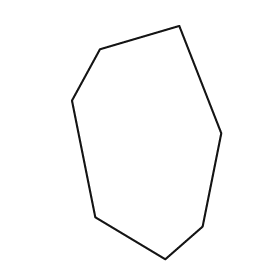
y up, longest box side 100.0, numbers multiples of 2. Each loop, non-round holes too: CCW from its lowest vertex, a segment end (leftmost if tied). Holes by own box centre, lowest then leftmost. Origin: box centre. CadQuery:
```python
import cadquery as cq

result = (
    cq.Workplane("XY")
    .moveTo(8.0, -50.0)
    .lineTo(24.0, -36.0)
    .lineTo(32.0, 4.0)
    .lineTo(14.0, 50.0)
    .lineTo(-20.0, 40.0)
    .lineTo(-32.0, 18.0)
    .lineTo(-22.0, -32.0)
    .close()
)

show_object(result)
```